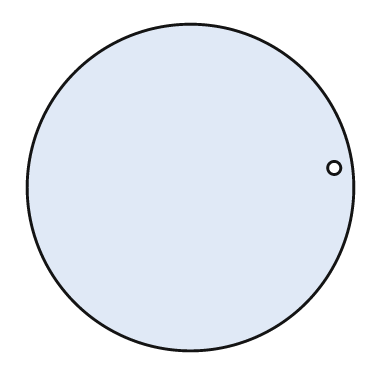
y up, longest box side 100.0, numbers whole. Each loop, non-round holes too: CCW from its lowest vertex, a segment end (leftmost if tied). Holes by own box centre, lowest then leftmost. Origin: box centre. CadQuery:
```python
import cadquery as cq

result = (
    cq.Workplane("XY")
    .moveTo(0.0, 0.0)
    .circle(50.0)
    .moveTo(44.0, 6.0)
    .circle(2.0)
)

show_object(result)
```